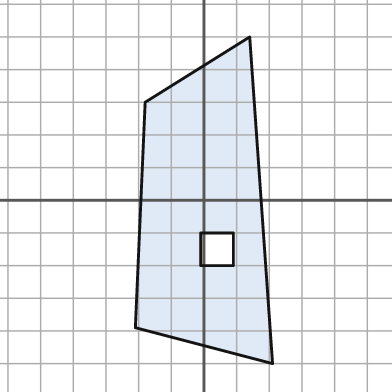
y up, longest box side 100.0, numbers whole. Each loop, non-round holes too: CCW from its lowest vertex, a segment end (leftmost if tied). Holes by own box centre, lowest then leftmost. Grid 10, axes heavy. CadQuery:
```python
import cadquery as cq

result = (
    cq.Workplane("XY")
    .moveTo(21.0, -50.0)
    .lineTo(14.0, 50.0)
    .lineTo(-18.0, 30.0)
    .lineTo(-21.0, -39.0)
    .close()
    .moveTo(-1.0, -20.0)
    .lineTo(9.0, -20.0)
    .lineTo(9.0, -10.0)
    .lineTo(-1.0, -10.0)
    .close()
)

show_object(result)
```